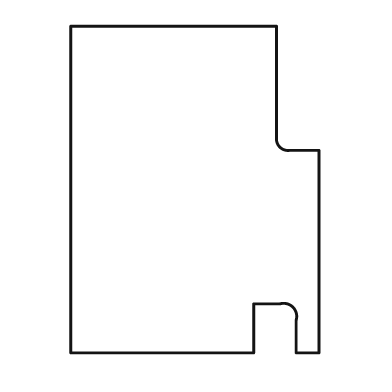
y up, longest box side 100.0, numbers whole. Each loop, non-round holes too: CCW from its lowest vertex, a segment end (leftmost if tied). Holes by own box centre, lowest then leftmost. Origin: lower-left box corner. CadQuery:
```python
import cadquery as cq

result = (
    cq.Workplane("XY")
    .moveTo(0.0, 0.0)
    .lineTo(56.0, 0.0)
    .lineTo(56.0, 15.0)
    .lineTo(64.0, 15.0)
    .threePointArc((68.0, 14.0), (69.0, 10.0))
    .lineTo(69.0, 0.0)
    .lineTo(76.0, 0.0)
    .lineTo(76.0, 62.0)
    .lineTo(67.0, 62.0)
    .threePointArc((64.0, 63.0), (63.0, 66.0))
    .lineTo(63.0, 100.0)
    .lineTo(0.0, 100.0)
    .close()
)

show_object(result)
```